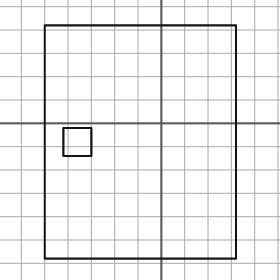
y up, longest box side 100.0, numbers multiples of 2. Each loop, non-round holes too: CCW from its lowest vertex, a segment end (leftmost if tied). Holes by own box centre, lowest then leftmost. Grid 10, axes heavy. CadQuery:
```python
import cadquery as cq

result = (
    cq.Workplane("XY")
    .moveTo(-50.0, -58.0)
    .lineTo(32.0, -58.0)
    .lineTo(32.0, 42.0)
    .lineTo(-50.0, 42.0)
    .close()
    .moveTo(-42.0, -14.0)
    .lineTo(-30.0, -14.0)
    .lineTo(-30.0, -2.0)
    .lineTo(-42.0, -2.0)
    .close()
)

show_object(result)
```